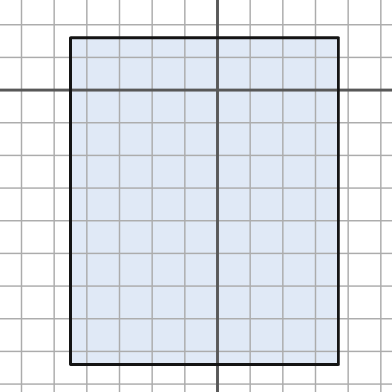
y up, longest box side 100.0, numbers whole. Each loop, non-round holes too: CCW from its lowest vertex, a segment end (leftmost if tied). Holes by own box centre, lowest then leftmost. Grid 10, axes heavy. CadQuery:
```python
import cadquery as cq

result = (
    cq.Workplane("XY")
    .moveTo(-45.0, -84.0)
    .lineTo(37.0, -84.0)
    .lineTo(37.0, 16.0)
    .lineTo(-45.0, 16.0)
    .close()
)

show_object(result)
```